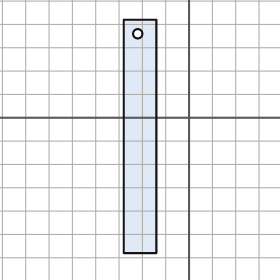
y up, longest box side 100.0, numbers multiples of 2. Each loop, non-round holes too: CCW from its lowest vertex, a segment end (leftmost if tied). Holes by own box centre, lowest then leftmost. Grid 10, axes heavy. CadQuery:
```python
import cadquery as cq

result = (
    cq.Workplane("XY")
    .moveTo(-28.0, -58.0)
    .lineTo(-14.0, -58.0)
    .lineTo(-14.0, 42.0)
    .lineTo(-28.0, 42.0)
    .close()
    .moveTo(-22.0, 36.0)
    .circle(2.0)
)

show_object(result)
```